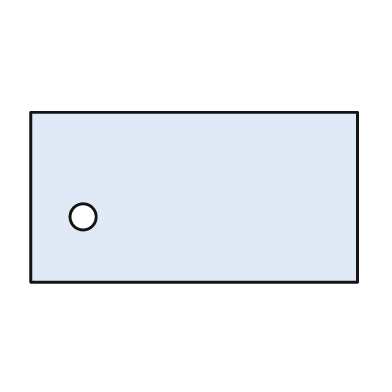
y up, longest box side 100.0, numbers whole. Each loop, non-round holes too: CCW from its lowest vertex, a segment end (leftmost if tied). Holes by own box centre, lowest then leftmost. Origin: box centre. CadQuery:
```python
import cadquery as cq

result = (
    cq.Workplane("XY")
    .moveTo(-50.0, -26.0)
    .lineTo(50.0, -26.0)
    .lineTo(50.0, 26.0)
    .lineTo(-50.0, 26.0)
    .close()
    .moveTo(-34.0, -6.0)
    .circle(4.0)
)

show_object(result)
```